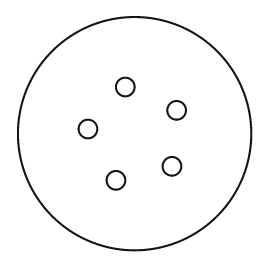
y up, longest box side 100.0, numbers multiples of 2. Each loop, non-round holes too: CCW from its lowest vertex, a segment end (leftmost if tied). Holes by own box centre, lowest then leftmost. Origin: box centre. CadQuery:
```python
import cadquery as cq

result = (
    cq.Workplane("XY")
    .moveTo(0.0, 0.0)
    .circle(50.0)
    .moveTo(-8.0, -20.0)
    .circle(4.0)
    .moveTo(16.0, -14.0)
    .circle(4.0)
    .moveTo(-20.0, 2.0)
    .circle(4.0)
    .moveTo(18.0, 10.0)
    .circle(4.0)
    .moveTo(-4.0, 20.0)
    .circle(4.0)
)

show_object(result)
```